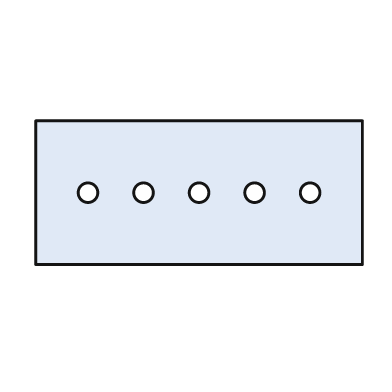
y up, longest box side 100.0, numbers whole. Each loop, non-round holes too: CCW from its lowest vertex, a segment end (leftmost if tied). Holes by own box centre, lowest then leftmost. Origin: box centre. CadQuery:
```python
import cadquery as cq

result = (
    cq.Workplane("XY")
    .moveTo(-50.0, -22.0)
    .lineTo(50.0, -22.0)
    .lineTo(50.0, 22.0)
    .lineTo(-50.0, 22.0)
    .close()
    .moveTo(-34.0, 0.0)
    .circle(3.0)
    .moveTo(-17.0, 0.0)
    .circle(3.0)
    .moveTo(0.0, 0.0)
    .circle(3.0)
    .moveTo(17.0, 0.0)
    .circle(3.0)
    .moveTo(34.0, 0.0)
    .circle(3.0)
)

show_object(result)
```